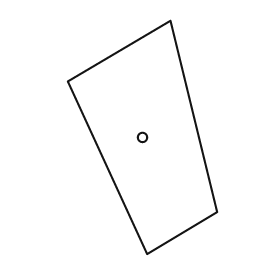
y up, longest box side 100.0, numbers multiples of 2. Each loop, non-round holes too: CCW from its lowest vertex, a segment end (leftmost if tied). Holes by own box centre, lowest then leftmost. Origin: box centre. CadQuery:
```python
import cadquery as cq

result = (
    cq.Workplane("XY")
    .moveTo(2.0, -50.0)
    .lineTo(32.0, -32.0)
    .lineTo(12.0, 50.0)
    .lineTo(-32.0, 24.0)
    .close()
    .moveTo(0.0, 0.0)
    .circle(2.0)
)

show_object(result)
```